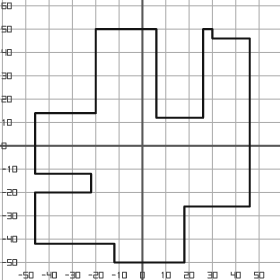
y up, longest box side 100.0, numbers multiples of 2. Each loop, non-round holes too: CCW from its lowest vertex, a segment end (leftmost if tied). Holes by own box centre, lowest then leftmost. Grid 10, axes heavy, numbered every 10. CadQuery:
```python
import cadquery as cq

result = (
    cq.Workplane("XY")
    .moveTo(-12.0, -50.0)
    .lineTo(18.0, -50.0)
    .lineTo(18.0, -26.0)
    .lineTo(46.0, -26.0)
    .lineTo(46.0, 46.0)
    .lineTo(30.0, 46.0)
    .lineTo(30.0, 50.0)
    .lineTo(26.0, 50.0)
    .lineTo(26.0, 12.0)
    .lineTo(6.0, 12.0)
    .lineTo(6.0, 50.0)
    .lineTo(-20.0, 50.0)
    .lineTo(-20.0, 14.0)
    .lineTo(-46.0, 14.0)
    .lineTo(-46.0, -12.0)
    .lineTo(-22.0, -12.0)
    .lineTo(-22.0, -20.0)
    .lineTo(-46.0, -20.0)
    .lineTo(-46.0, -42.0)
    .lineTo(-12.0, -42.0)
    .close()
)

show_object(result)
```